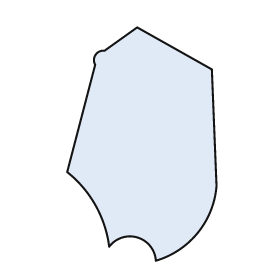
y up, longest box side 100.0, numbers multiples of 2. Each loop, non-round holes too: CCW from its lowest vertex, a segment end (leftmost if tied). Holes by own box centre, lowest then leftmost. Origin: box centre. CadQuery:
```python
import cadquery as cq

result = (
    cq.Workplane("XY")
    .moveTo(6.0, -50.0)
    .threePointArc((24.0, -38.0), (32.0, -18.0))
    .lineTo(30.0, 32.0)
    .lineTo(-2.0, 50.0)
    .lineTo(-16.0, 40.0)
    .threePointArc((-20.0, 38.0), (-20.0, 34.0))
    .lineTo(-32.0, -12.0)
    .threePointArc((-20.0, -26.0), (-14.0, -44.0))
    .threePointArc((-2.0, -40.0), (6.0, -50.0))
    .close()
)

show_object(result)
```